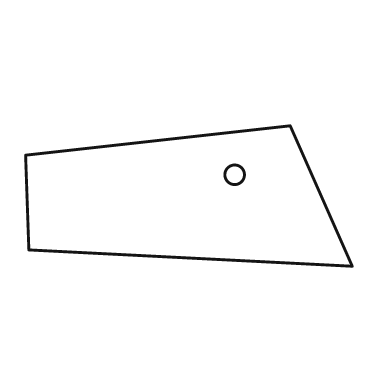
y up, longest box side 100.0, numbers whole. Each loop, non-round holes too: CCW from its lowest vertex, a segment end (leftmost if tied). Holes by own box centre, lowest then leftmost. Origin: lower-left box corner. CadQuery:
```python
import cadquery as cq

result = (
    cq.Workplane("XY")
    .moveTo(100.0, 0.0)
    .lineTo(81.0, 43.0)
    .lineTo(0.0, 34.0)
    .lineTo(1.0, 5.0)
    .close()
    .moveTo(64.0, 28.0)
    .circle(3.0)
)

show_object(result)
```